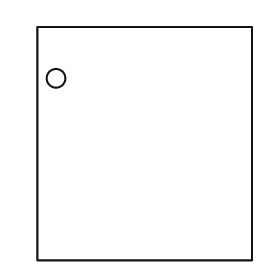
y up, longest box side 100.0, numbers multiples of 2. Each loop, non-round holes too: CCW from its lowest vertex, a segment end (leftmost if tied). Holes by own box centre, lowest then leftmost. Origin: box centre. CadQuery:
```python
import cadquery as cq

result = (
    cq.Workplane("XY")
    .moveTo(-46.0, -50.0)
    .lineTo(46.0, -50.0)
    .lineTo(46.0, 50.0)
    .lineTo(-46.0, 50.0)
    .close()
    .moveTo(-38.0, 28.0)
    .circle(4.0)
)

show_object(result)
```